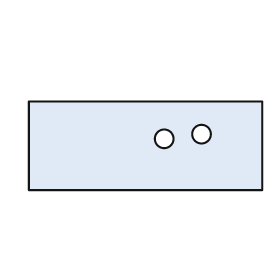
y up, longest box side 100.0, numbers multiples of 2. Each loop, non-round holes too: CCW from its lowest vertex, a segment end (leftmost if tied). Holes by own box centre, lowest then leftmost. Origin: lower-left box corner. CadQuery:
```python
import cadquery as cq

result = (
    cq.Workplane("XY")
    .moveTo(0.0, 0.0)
    .lineTo(100.0, 0.0)
    .lineTo(100.0, 38.0)
    .lineTo(0.0, 38.0)
    .close()
    .moveTo(58.0, 22.0)
    .circle(4.0)
    .moveTo(74.0, 24.0)
    .circle(4.0)
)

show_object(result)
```